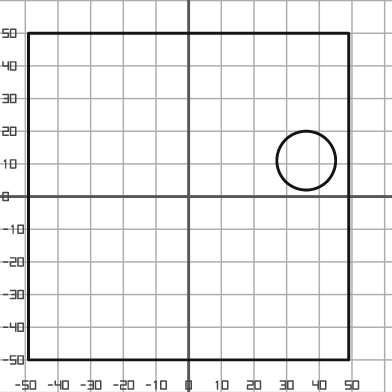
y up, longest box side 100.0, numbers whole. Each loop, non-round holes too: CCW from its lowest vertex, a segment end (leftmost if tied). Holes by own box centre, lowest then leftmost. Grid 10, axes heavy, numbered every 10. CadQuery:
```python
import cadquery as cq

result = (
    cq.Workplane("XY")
    .moveTo(-49.0, -50.0)
    .lineTo(49.0, -50.0)
    .lineTo(49.0, 50.0)
    .lineTo(-49.0, 50.0)
    .close()
    .moveTo(36.0, 11.0)
    .circle(9.0)
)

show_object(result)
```